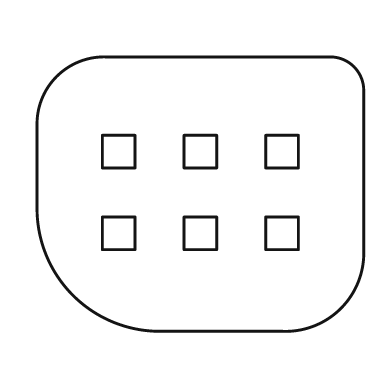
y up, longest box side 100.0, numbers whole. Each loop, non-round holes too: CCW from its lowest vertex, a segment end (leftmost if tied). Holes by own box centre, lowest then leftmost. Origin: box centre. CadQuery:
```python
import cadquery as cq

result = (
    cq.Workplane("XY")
    .moveTo(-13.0, -42.0)
    .lineTo(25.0, -42.0)
    .threePointArc((43.0, -35.0), (50.0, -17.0))
    .lineTo(50.0, 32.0)
    .threePointArc((47.0, 39.0), (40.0, 42.0))
    .lineTo(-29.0, 42.0)
    .threePointArc((-44.0, 36.0), (-50.0, 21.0))
    .lineTo(-50.0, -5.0)
    .threePointArc((-39.0, -31.0), (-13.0, -42.0))
    .close()
    .moveTo(-30.0, -17.0)
    .lineTo(-20.0, -17.0)
    .lineTo(-20.0, -7.0)
    .lineTo(-30.0, -7.0)
    .close()
    .moveTo(-5.0, -17.0)
    .lineTo(5.0, -17.0)
    .lineTo(5.0, -7.0)
    .lineTo(-5.0, -7.0)
    .close()
    .moveTo(20.0, -17.0)
    .lineTo(30.0, -17.0)
    .lineTo(30.0, -7.0)
    .lineTo(20.0, -7.0)
    .close()
    .moveTo(-30.0, 8.0)
    .lineTo(-20.0, 8.0)
    .lineTo(-20.0, 18.0)
    .lineTo(-30.0, 18.0)
    .close()
    .moveTo(-5.0, 8.0)
    .lineTo(5.0, 8.0)
    .lineTo(5.0, 18.0)
    .lineTo(-5.0, 18.0)
    .close()
    .moveTo(20.0, 8.0)
    .lineTo(30.0, 8.0)
    .lineTo(30.0, 18.0)
    .lineTo(20.0, 18.0)
    .close()
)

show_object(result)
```